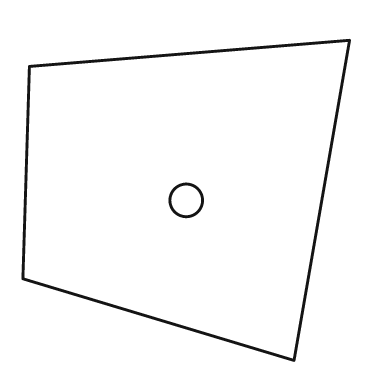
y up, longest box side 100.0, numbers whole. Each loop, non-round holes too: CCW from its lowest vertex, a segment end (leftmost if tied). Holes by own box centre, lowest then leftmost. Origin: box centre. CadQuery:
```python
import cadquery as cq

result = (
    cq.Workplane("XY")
    .moveTo(33.0, -49.0)
    .lineTo(50.0, 49.0)
    .lineTo(-48.0, 41.0)
    .lineTo(-50.0, -24.0)
    .close()
    .moveTo(0.0, 0.0)
    .circle(5.0)
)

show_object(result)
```